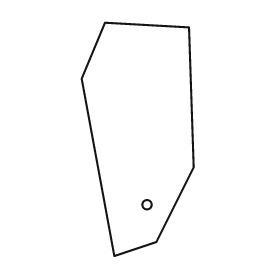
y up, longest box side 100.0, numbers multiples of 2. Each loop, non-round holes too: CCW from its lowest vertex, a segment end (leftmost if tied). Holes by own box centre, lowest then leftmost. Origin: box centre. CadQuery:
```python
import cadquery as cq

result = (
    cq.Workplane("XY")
    .moveTo(-10.0, -50.0)
    .lineTo(8.0, -44.0)
    .lineTo(24.0, -12.0)
    .lineTo(22.0, 48.0)
    .lineTo(-14.0, 50.0)
    .lineTo(-24.0, 26.0)
    .close()
    .moveTo(4.0, -28.0)
    .circle(2.0)
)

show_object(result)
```